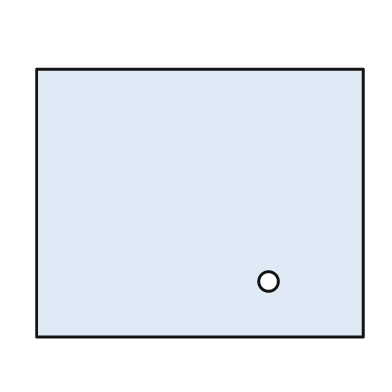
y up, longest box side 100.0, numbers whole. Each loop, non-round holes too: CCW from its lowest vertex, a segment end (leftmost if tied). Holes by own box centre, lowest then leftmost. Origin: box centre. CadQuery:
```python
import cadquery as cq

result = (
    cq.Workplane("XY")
    .moveTo(-50.0, -41.0)
    .lineTo(50.0, -41.0)
    .lineTo(50.0, 41.0)
    .lineTo(-50.0, 41.0)
    .close()
    .moveTo(21.0, -24.0)
    .circle(3.0)
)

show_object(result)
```